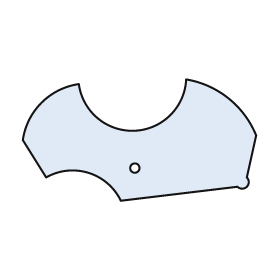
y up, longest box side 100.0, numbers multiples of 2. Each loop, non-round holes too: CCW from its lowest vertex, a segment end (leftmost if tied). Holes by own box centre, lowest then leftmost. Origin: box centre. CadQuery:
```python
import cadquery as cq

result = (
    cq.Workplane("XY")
    .moveTo(-8.0, -26.0)
    .lineTo(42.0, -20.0)
    .threePointArc((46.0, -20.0), (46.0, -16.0))
    .lineTo(50.0, 2.0)
    .threePointArc((38.0, 18.0), (20.0, 26.0))
    .threePointArc((-2.0, 4.0), (-26.0, 24.0))
    .threePointArc((-42.0, 16.0), (-50.0, 0.0))
    .lineTo(-40.0, -16.0)
    .threePointArc((-22.0, -14.0), (-8.0, -26.0))
    .close()
    .moveTo(-2.0, -12.0)
    .circle(2.0)
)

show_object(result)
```